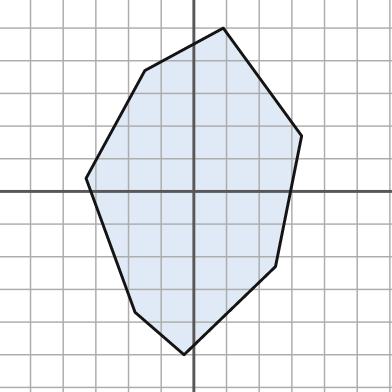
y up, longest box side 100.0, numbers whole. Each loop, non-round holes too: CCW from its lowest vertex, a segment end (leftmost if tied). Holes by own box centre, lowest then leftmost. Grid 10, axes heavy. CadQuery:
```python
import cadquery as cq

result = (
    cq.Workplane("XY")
    .moveTo(-3.0, -50.0)
    .lineTo(25.0, -23.0)
    .lineTo(33.0, 17.0)
    .lineTo(9.0, 50.0)
    .lineTo(-15.0, 37.0)
    .lineTo(-33.0, 4.0)
    .lineTo(-18.0, -37.0)
    .close()
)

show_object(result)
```